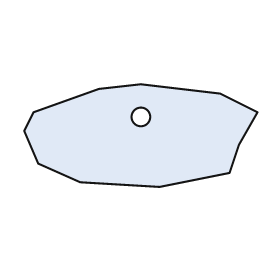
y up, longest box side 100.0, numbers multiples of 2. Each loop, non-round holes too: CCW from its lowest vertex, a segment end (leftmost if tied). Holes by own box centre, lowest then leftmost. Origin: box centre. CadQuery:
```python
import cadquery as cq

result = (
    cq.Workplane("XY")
    .moveTo(8.0, -22.0)
    .lineTo(38.0, -16.0)
    .lineTo(42.0, -4.0)
    .lineTo(50.0, 10.0)
    .lineTo(34.0, 18.0)
    .lineTo(0.0, 22.0)
    .lineTo(-18.0, 20.0)
    .lineTo(-46.0, 10.0)
    .lineTo(-50.0, 2.0)
    .lineTo(-44.0, -12.0)
    .lineTo(-26.0, -20.0)
    .close()
    .moveTo(0.0, 8.0)
    .circle(4.0)
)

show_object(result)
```